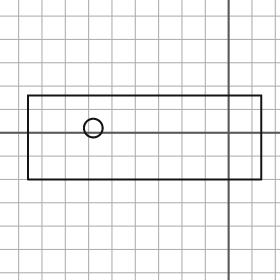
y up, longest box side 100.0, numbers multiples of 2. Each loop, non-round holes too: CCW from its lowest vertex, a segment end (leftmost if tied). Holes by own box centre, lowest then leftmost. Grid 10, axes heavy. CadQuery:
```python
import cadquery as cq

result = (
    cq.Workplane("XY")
    .moveTo(-86.0, -20.0)
    .lineTo(14.0, -20.0)
    .lineTo(14.0, 16.0)
    .lineTo(-86.0, 16.0)
    .close()
    .moveTo(-58.0, 2.0)
    .circle(4.0)
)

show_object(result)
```